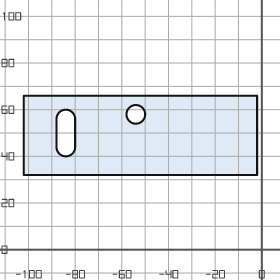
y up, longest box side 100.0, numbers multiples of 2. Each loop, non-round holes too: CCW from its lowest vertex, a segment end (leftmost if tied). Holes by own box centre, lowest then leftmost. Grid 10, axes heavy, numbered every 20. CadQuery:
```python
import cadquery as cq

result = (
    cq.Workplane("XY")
    .moveTo(-102.0, 32.0)
    .lineTo(-2.0, 32.0)
    .lineTo(-2.0, 66.0)
    .lineTo(-102.0, 66.0)
    .close()
    .moveTo(-88.0, 44.0)
    .threePointArc((-84.0, 40.0), (-80.0, 44.0))
    .lineTo(-80.0, 56.0)
    .threePointArc((-84.0, 60.0), (-88.0, 56.0))
    .close()
    .moveTo(-54.0, 58.0)
    .circle(4.0)
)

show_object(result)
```